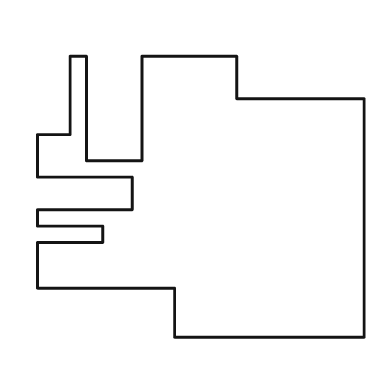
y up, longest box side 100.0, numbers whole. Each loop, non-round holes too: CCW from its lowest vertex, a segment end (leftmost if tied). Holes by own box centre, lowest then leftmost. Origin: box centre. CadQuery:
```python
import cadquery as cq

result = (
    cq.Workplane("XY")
    .moveTo(-8.0, -43.0)
    .lineTo(50.0, -43.0)
    .lineTo(50.0, 30.0)
    .lineTo(11.0, 30.0)
    .lineTo(11.0, 43.0)
    .lineTo(-18.0, 43.0)
    .lineTo(-18.0, 11.0)
    .lineTo(-35.0, 11.0)
    .lineTo(-35.0, 43.0)
    .lineTo(-40.0, 43.0)
    .lineTo(-40.0, 19.0)
    .lineTo(-50.0, 19.0)
    .lineTo(-50.0, 6.0)
    .lineTo(-21.0, 6.0)
    .lineTo(-21.0, -4.0)
    .lineTo(-50.0, -4.0)
    .lineTo(-50.0, -9.0)
    .lineTo(-30.0, -9.0)
    .lineTo(-30.0, -14.0)
    .lineTo(-50.0, -14.0)
    .lineTo(-50.0, -28.0)
    .lineTo(-8.0, -28.0)
    .close()
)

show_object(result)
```